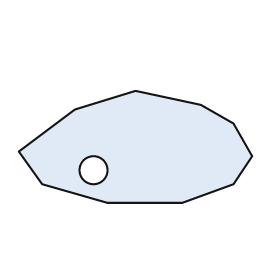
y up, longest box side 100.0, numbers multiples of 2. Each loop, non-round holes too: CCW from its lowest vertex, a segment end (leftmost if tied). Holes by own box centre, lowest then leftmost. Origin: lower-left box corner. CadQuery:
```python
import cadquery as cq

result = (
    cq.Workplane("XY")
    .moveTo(38.0, 0.0)
    .lineTo(70.0, 0.0)
    .lineTo(92.0, 8.0)
    .lineTo(100.0, 20.0)
    .lineTo(92.0, 34.0)
    .lineTo(78.0, 42.0)
    .lineTo(50.0, 48.0)
    .lineTo(24.0, 40.0)
    .lineTo(0.0, 22.0)
    .lineTo(10.0, 8.0)
    .close()
    .moveTo(32.0, 14.0)
    .circle(6.0)
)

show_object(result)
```